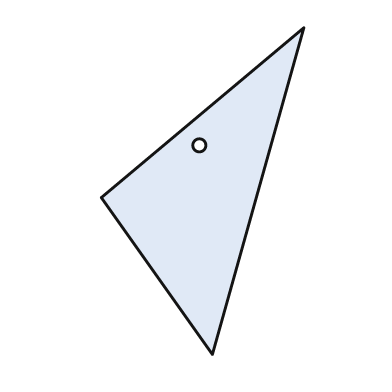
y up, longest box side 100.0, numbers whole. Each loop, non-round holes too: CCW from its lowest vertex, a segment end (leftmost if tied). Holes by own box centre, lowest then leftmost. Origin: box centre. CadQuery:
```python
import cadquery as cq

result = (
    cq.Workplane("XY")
    .moveTo(3.0, -50.0)
    .lineTo(31.0, 50.0)
    .lineTo(-31.0, -2.0)
    .close()
    .moveTo(-1.0, 14.0)
    .circle(2.0)
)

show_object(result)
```